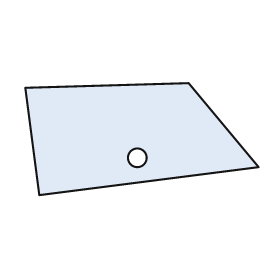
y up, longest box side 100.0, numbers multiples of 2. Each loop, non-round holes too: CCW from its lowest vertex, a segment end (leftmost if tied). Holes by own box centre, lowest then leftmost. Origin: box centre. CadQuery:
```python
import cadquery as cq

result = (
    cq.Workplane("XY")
    .moveTo(-44.0, -24.0)
    .lineTo(50.0, -12.0)
    .lineTo(20.0, 24.0)
    .lineTo(-50.0, 22.0)
    .close()
    .moveTo(-2.0, -8.0)
    .circle(4.0)
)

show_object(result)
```